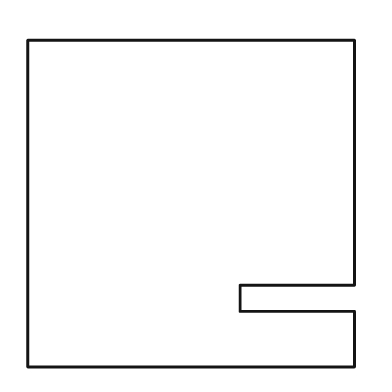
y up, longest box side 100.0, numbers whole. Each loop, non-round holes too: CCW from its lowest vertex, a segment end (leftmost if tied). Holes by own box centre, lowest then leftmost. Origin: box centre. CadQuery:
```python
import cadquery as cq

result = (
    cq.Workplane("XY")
    .moveTo(-50.0, -50.0)
    .lineTo(50.0, -50.0)
    .lineTo(50.0, -33.0)
    .lineTo(15.0, -33.0)
    .lineTo(15.0, -25.0)
    .lineTo(50.0, -25.0)
    .lineTo(50.0, 50.0)
    .lineTo(-50.0, 50.0)
    .close()
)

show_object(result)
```